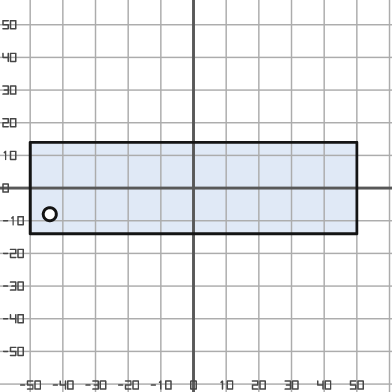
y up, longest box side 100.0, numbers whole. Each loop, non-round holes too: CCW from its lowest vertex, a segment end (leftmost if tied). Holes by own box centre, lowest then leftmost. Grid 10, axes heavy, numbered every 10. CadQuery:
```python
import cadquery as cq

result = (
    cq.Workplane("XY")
    .moveTo(-50.0, -14.0)
    .lineTo(50.0, -14.0)
    .lineTo(50.0, 14.0)
    .lineTo(-50.0, 14.0)
    .close()
    .moveTo(-44.0, -8.0)
    .circle(2.0)
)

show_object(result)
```